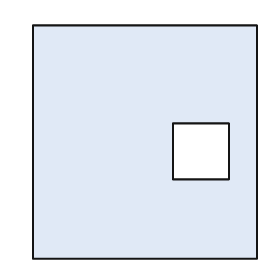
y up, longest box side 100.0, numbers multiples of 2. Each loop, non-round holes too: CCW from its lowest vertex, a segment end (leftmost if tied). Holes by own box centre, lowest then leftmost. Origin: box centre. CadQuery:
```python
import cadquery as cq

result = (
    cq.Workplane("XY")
    .moveTo(-48.0, -50.0)
    .lineTo(48.0, -50.0)
    .lineTo(48.0, 50.0)
    .lineTo(-48.0, 50.0)
    .close()
    .moveTo(12.0, -16.0)
    .lineTo(36.0, -16.0)
    .lineTo(36.0, 8.0)
    .lineTo(12.0, 8.0)
    .close()
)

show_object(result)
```